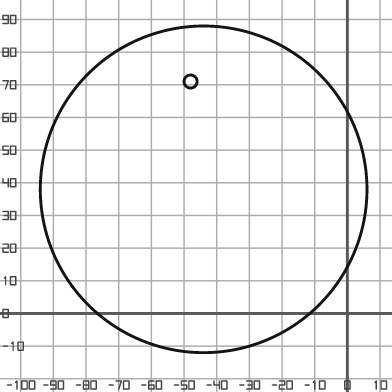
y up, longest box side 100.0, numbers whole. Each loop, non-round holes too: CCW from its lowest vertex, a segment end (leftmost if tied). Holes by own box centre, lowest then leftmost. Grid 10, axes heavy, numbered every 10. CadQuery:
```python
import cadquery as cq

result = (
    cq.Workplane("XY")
    .moveTo(-44.0, 38.0)
    .circle(50.0)
    .moveTo(-48.0, 71.0)
    .circle(2.0)
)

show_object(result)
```